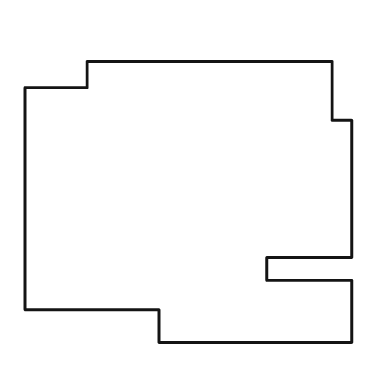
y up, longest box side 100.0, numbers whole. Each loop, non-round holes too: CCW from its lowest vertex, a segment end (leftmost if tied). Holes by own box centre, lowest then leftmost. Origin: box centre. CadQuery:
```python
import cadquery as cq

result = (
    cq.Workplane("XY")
    .moveTo(-9.0, -43.0)
    .lineTo(50.0, -43.0)
    .lineTo(50.0, -24.0)
    .lineTo(24.0, -24.0)
    .lineTo(24.0, -17.0)
    .lineTo(50.0, -17.0)
    .lineTo(50.0, 25.0)
    .lineTo(44.0, 25.0)
    .lineTo(44.0, 43.0)
    .lineTo(-31.0, 43.0)
    .lineTo(-31.0, 35.0)
    .lineTo(-50.0, 35.0)
    .lineTo(-50.0, -33.0)
    .lineTo(-9.0, -33.0)
    .close()
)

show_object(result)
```